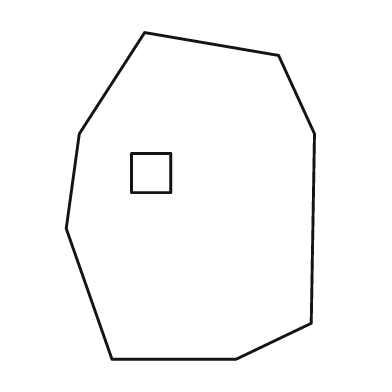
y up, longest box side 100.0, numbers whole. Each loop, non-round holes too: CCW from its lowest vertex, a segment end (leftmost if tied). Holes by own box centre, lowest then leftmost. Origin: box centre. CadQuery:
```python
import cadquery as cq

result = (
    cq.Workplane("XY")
    .moveTo(-24.0, -50.0)
    .lineTo(14.0, -50.0)
    .lineTo(37.0, -39.0)
    .lineTo(38.0, 19.0)
    .lineTo(27.0, 43.0)
    .lineTo(-14.0, 50.0)
    .lineTo(-34.0, 19.0)
    .lineTo(-38.0, -10.0)
    .close()
    .moveTo(-18.0, 1.0)
    .lineTo(-6.0, 1.0)
    .lineTo(-6.0, 13.0)
    .lineTo(-18.0, 13.0)
    .close()
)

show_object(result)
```